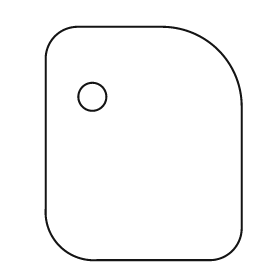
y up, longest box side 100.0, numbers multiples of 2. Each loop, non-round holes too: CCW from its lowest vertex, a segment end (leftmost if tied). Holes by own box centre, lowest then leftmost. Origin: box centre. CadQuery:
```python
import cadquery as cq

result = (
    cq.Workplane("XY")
    .moveTo(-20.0, -50.0)
    .lineTo(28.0, -50.0)
    .threePointArc((38.0, -46.0), (42.0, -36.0))
    .lineTo(42.0, 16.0)
    .threePointArc((32.0, 40.0), (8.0, 50.0))
    .lineTo(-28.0, 50.0)
    .threePointArc((-38.0, 46.0), (-42.0, 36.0))
    .lineTo(-42.0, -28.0)
    .threePointArc((-36.0, -44.0), (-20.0, -50.0))
    .close()
    .moveTo(-22.0, 20.0)
    .circle(6.0)
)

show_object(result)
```